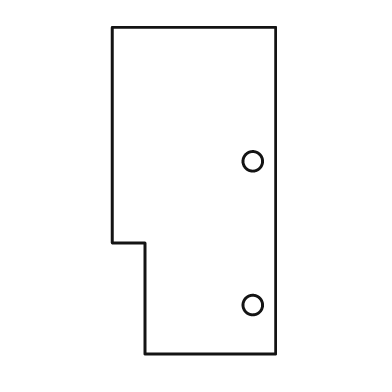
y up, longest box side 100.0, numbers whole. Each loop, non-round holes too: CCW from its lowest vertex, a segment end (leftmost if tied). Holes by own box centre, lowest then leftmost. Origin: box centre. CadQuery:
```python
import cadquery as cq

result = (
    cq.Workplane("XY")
    .moveTo(-15.0, -50.0)
    .lineTo(25.0, -50.0)
    .lineTo(25.0, 50.0)
    .lineTo(-25.0, 50.0)
    .lineTo(-25.0, -16.0)
    .lineTo(-15.0, -16.0)
    .close()
    .moveTo(18.0, -35.0)
    .circle(3.0)
    .moveTo(18.0, 9.0)
    .circle(3.0)
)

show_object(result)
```